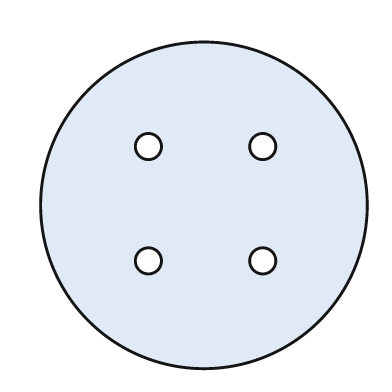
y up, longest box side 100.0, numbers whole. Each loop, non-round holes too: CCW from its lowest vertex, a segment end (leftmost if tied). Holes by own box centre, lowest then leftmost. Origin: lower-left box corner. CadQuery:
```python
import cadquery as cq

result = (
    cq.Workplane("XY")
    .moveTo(50.0, 50.0)
    .circle(50.0)
    .moveTo(33.0, 33.0)
    .circle(4.0)
    .moveTo(68.0, 33.0)
    .circle(4.0)
    .moveTo(33.0, 68.0)
    .circle(4.0)
    .moveTo(68.0, 68.0)
    .circle(4.0)
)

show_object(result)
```